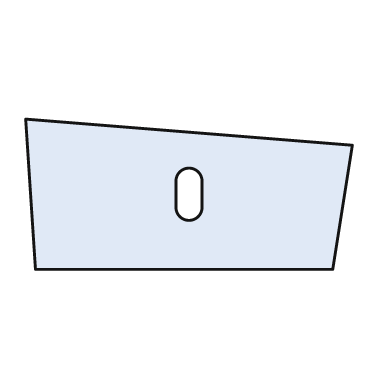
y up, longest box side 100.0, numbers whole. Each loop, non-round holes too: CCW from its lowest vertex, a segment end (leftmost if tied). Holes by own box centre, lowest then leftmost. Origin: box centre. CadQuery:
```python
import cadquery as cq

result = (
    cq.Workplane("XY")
    .moveTo(-47.0, -23.0)
    .lineTo(44.0, -23.0)
    .lineTo(50.0, 15.0)
    .lineTo(-50.0, 23.0)
    .close()
    .moveTo(-4.0, -4.0)
    .threePointArc((0.0, -8.0), (4.0, -4.0))
    .lineTo(4.0, 4.0)
    .threePointArc((0.0, 8.0), (-4.0, 4.0))
    .close()
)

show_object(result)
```